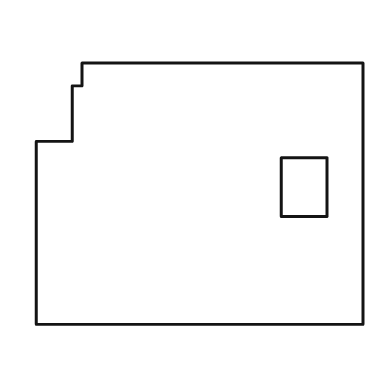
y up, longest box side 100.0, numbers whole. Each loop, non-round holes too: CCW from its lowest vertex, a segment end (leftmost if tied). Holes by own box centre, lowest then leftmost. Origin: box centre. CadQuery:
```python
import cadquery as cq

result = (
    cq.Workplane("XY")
    .moveTo(-50.0, -40.0)
    .lineTo(50.0, -40.0)
    .lineTo(50.0, 40.0)
    .lineTo(-36.0, 40.0)
    .lineTo(-36.0, 33.0)
    .lineTo(-39.0, 33.0)
    .lineTo(-39.0, 16.0)
    .lineTo(-50.0, 16.0)
    .close()
    .moveTo(25.0, -7.0)
    .lineTo(39.0, -7.0)
    .lineTo(39.0, 11.0)
    .lineTo(25.0, 11.0)
    .close()
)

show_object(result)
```